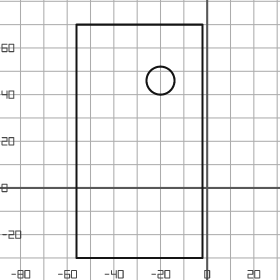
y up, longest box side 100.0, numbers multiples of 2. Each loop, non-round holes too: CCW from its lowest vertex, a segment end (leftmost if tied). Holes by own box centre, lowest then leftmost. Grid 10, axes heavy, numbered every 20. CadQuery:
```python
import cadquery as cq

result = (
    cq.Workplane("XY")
    .moveTo(-56.0, -30.0)
    .lineTo(-2.0, -30.0)
    .lineTo(-2.0, 70.0)
    .lineTo(-56.0, 70.0)
    .close()
    .moveTo(-20.0, 46.0)
    .circle(6.0)
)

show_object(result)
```